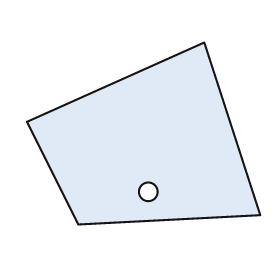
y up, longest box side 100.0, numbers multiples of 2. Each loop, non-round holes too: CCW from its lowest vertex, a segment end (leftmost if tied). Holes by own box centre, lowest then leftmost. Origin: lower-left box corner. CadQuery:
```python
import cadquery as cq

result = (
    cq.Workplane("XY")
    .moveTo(22.0, 0.0)
    .lineTo(100.0, 4.0)
    .lineTo(76.0, 78.0)
    .lineTo(0.0, 44.0)
    .close()
    .moveTo(52.0, 14.0)
    .circle(4.0)
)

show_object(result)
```